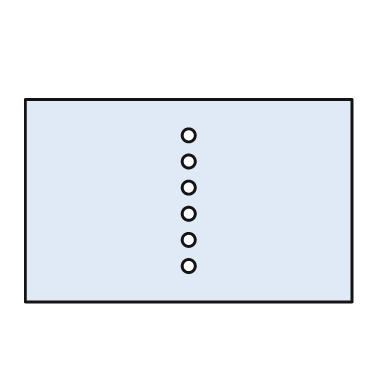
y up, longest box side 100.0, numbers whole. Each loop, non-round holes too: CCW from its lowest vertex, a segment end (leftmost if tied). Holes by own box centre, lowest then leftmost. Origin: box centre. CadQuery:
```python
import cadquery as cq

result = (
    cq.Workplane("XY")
    .moveTo(-50.0, -31.0)
    .lineTo(50.0, -31.0)
    .lineTo(50.0, 31.0)
    .lineTo(-50.0, 31.0)
    .close()
    .moveTo(0.0, -20.0)
    .circle(2.0)
    .moveTo(0.0, -12.0)
    .circle(2.0)
    .moveTo(0.0, -4.0)
    .circle(2.0)
    .moveTo(0.0, 4.0)
    .circle(2.0)
    .moveTo(0.0, 12.0)
    .circle(2.0)
    .moveTo(0.0, 20.0)
    .circle(2.0)
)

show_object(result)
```